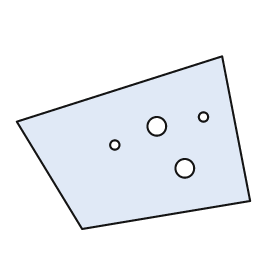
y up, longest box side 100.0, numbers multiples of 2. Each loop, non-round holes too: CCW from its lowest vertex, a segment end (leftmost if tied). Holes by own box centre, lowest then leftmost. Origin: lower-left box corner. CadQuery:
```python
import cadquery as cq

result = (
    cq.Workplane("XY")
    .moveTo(28.0, 0.0)
    .lineTo(100.0, 12.0)
    .lineTo(88.0, 74.0)
    .lineTo(0.0, 46.0)
    .close()
    .moveTo(72.0, 26.0)
    .circle(4.0)
    .moveTo(42.0, 36.0)
    .circle(2.0)
    .moveTo(60.0, 44.0)
    .circle(4.0)
    .moveTo(80.0, 48.0)
    .circle(2.0)
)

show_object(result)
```